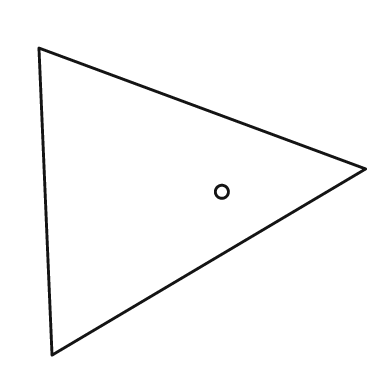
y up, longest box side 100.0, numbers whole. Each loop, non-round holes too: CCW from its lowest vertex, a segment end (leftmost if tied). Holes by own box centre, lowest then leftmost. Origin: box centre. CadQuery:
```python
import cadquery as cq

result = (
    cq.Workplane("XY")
    .moveTo(-46.0, -47.0)
    .lineTo(50.0, 10.0)
    .lineTo(-50.0, 47.0)
    .close()
    .moveTo(6.0, 3.0)
    .circle(2.0)
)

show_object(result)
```